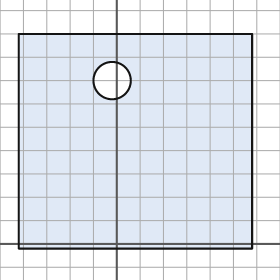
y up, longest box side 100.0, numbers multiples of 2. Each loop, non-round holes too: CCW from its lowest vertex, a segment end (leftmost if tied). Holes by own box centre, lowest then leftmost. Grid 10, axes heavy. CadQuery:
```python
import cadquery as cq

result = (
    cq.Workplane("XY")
    .moveTo(-42.0, -2.0)
    .lineTo(58.0, -2.0)
    .lineTo(58.0, 90.0)
    .lineTo(-42.0, 90.0)
    .close()
    .moveTo(-2.0, 70.0)
    .circle(8.0)
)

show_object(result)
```